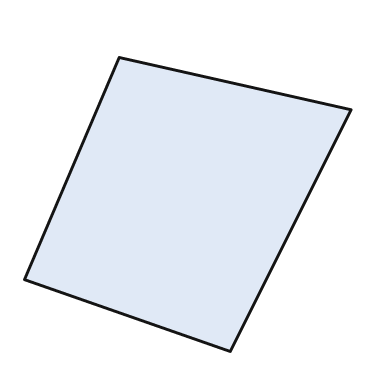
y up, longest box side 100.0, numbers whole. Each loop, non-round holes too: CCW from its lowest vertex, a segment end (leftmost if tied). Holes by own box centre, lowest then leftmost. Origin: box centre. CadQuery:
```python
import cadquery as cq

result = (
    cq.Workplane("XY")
    .moveTo(13.0, -45.0)
    .lineTo(50.0, 29.0)
    .lineTo(-21.0, 45.0)
    .lineTo(-50.0, -23.0)
    .close()
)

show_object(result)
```